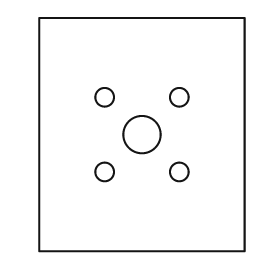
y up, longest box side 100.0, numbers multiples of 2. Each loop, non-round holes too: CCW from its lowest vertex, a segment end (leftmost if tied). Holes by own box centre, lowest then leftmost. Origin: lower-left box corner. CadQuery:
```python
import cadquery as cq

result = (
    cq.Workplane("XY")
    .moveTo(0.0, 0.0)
    .lineTo(88.0, 0.0)
    .lineTo(88.0, 100.0)
    .lineTo(0.0, 100.0)
    .close()
    .moveTo(28.0, 34.0)
    .circle(4.0)
    .moveTo(60.0, 34.0)
    .circle(4.0)
    .moveTo(44.0, 50.0)
    .circle(8.0)
    .moveTo(28.0, 66.0)
    .circle(4.0)
    .moveTo(60.0, 66.0)
    .circle(4.0)
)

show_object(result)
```